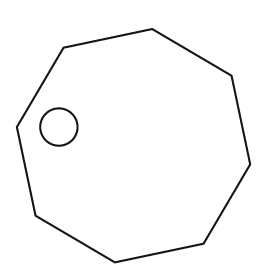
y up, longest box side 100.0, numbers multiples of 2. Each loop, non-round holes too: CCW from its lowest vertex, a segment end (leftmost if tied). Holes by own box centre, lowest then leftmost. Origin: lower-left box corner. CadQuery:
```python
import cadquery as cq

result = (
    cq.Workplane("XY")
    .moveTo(42.0, 0.0)
    .lineTo(80.0, 8.0)
    .lineTo(100.0, 42.0)
    .lineTo(92.0, 80.0)
    .lineTo(58.0, 100.0)
    .lineTo(20.0, 92.0)
    .lineTo(0.0, 58.0)
    .lineTo(8.0, 20.0)
    .close()
    .moveTo(18.0, 58.0)
    .circle(8.0)
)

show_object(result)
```